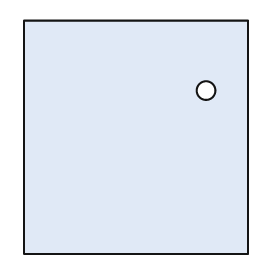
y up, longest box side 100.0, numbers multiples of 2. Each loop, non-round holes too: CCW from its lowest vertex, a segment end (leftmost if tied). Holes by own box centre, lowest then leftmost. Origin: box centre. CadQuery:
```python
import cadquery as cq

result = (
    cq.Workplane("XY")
    .moveTo(-48.0, -50.0)
    .lineTo(48.0, -50.0)
    .lineTo(48.0, 50.0)
    .lineTo(-48.0, 50.0)
    .close()
    .moveTo(30.0, 20.0)
    .circle(4.0)
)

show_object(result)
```